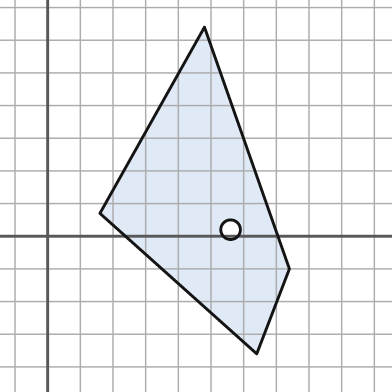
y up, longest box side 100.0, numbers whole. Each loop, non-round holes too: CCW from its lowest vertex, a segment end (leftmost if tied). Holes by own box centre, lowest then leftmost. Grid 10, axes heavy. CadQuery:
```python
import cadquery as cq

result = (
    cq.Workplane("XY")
    .moveTo(64.0, -36.0)
    .lineTo(74.0, -10.0)
    .lineTo(48.0, 64.0)
    .lineTo(16.0, 7.0)
    .close()
    .moveTo(56.0, 2.0)
    .circle(3.0)
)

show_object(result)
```